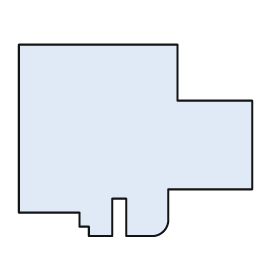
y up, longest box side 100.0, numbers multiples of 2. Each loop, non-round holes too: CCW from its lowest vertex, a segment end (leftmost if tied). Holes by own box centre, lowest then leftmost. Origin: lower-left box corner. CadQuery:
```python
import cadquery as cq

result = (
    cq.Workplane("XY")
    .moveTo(30.0, 0.0)
    .lineTo(40.0, 0.0)
    .lineTo(40.0, 16.0)
    .lineTo(46.0, 16.0)
    .lineTo(46.0, 0.0)
    .lineTo(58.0, 0.0)
    .threePointArc((62.0, 2.0), (64.0, 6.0))
    .lineTo(64.0, 20.0)
    .lineTo(100.0, 20.0)
    .lineTo(100.0, 58.0)
    .lineTo(68.0, 58.0)
    .lineTo(68.0, 82.0)
    .lineTo(0.0, 82.0)
    .lineTo(0.0, 10.0)
    .lineTo(26.0, 10.0)
    .lineTo(26.0, 4.0)
    .lineTo(30.0, 4.0)
    .close()
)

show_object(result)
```